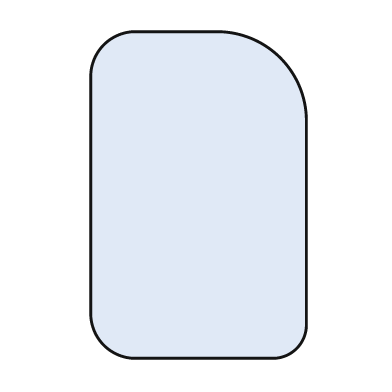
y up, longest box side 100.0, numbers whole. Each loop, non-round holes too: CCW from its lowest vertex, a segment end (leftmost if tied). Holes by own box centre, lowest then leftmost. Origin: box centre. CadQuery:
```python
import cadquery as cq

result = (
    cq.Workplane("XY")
    .moveTo(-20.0, -50.0)
    .lineTo(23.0, -50.0)
    .threePointArc((30.0, -47.0), (33.0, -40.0))
    .lineTo(33.0, 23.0)
    .threePointArc((25.0, 42.0), (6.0, 50.0))
    .lineTo(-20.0, 50.0)
    .threePointArc((-29.0, 46.0), (-33.0, 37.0))
    .lineTo(-33.0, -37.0)
    .threePointArc((-29.0, -46.0), (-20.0, -50.0))
    .close()
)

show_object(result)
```